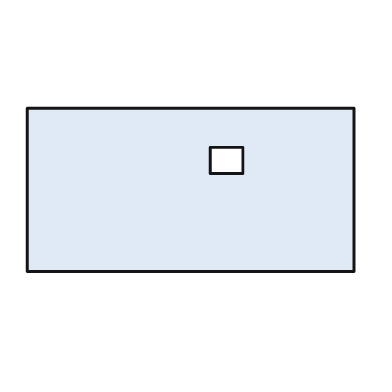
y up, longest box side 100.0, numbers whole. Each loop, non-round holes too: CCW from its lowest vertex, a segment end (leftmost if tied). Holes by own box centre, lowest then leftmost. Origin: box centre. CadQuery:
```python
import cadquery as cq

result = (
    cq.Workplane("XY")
    .moveTo(-50.0, -25.0)
    .lineTo(50.0, -25.0)
    .lineTo(50.0, 25.0)
    .lineTo(-50.0, 25.0)
    .close()
    .moveTo(6.0, 5.0)
    .lineTo(16.0, 5.0)
    .lineTo(16.0, 13.0)
    .lineTo(6.0, 13.0)
    .close()
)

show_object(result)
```